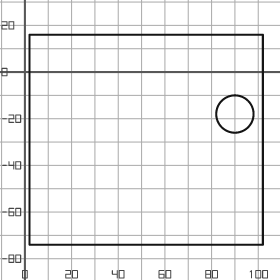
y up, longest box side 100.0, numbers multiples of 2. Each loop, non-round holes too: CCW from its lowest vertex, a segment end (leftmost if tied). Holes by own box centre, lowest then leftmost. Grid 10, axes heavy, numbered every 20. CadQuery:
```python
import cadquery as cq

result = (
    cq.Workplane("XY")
    .moveTo(2.0, -74.0)
    .lineTo(102.0, -74.0)
    .lineTo(102.0, 16.0)
    .lineTo(2.0, 16.0)
    .close()
    .moveTo(90.0, -18.0)
    .circle(8.0)
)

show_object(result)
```